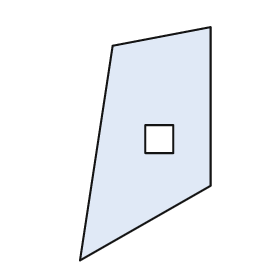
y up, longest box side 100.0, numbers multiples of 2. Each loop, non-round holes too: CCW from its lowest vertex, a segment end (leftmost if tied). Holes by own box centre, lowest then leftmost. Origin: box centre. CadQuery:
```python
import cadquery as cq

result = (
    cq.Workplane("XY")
    .moveTo(-28.0, -50.0)
    .lineTo(28.0, -18.0)
    .lineTo(28.0, 50.0)
    .lineTo(-14.0, 42.0)
    .close()
    .moveTo(0.0, -4.0)
    .lineTo(12.0, -4.0)
    .lineTo(12.0, 8.0)
    .lineTo(0.0, 8.0)
    .close()
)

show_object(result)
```